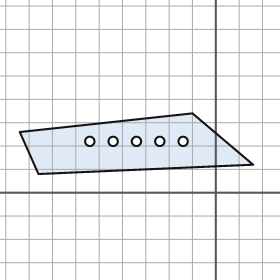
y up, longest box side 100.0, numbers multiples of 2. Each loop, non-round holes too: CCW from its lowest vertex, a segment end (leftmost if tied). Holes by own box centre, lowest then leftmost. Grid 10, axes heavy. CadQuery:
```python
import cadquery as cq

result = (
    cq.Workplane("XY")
    .moveTo(-76.0, 8.0)
    .lineTo(16.0, 12.0)
    .lineTo(-10.0, 34.0)
    .lineTo(-84.0, 26.0)
    .close()
    .moveTo(-54.0, 22.0)
    .circle(2.0)
    .moveTo(-44.0, 22.0)
    .circle(2.0)
    .moveTo(-34.0, 22.0)
    .circle(2.0)
    .moveTo(-24.0, 22.0)
    .circle(2.0)
    .moveTo(-14.0, 22.0)
    .circle(2.0)
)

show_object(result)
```